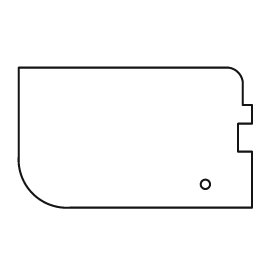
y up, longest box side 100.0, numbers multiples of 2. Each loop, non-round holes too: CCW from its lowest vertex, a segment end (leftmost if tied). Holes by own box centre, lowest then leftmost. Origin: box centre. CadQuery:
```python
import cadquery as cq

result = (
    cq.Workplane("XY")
    .moveTo(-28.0, -30.0)
    .lineTo(50.0, -30.0)
    .lineTo(50.0, -6.0)
    .lineTo(44.0, -6.0)
    .lineTo(44.0, 6.0)
    .lineTo(50.0, 6.0)
    .lineTo(50.0, 14.0)
    .lineTo(46.0, 14.0)
    .lineTo(46.0, 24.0)
    .threePointArc((44.0, 28.0), (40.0, 30.0))
    .lineTo(-50.0, 30.0)
    .lineTo(-50.0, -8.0)
    .threePointArc((-44.0, -24.0), (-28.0, -30.0))
    .close()
    .moveTo(30.0, -20.0)
    .circle(2.0)
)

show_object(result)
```